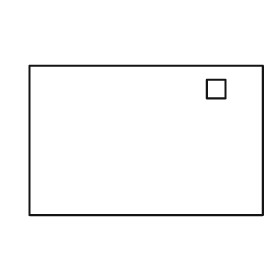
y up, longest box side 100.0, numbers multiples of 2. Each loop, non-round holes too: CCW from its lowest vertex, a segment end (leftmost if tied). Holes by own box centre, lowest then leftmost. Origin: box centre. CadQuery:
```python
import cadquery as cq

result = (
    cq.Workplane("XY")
    .moveTo(-50.0, -32.0)
    .lineTo(50.0, -32.0)
    .lineTo(50.0, 32.0)
    .lineTo(-50.0, 32.0)
    .close()
    .moveTo(26.0, 18.0)
    .lineTo(34.0, 18.0)
    .lineTo(34.0, 26.0)
    .lineTo(26.0, 26.0)
    .close()
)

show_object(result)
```